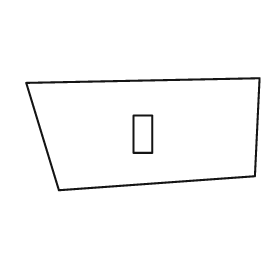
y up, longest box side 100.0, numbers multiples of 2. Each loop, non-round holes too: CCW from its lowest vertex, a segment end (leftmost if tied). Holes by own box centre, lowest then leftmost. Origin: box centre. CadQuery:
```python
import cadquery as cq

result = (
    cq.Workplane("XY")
    .moveTo(-36.0, -24.0)
    .lineTo(48.0, -18.0)
    .lineTo(50.0, 24.0)
    .lineTo(-50.0, 22.0)
    .close()
    .moveTo(-4.0, -8.0)
    .lineTo(4.0, -8.0)
    .lineTo(4.0, 8.0)
    .lineTo(-4.0, 8.0)
    .close()
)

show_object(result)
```